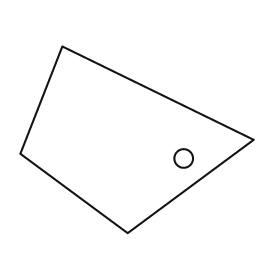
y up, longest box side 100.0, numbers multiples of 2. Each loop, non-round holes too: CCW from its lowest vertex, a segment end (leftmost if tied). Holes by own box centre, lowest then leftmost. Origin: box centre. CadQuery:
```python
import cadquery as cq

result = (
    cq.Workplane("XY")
    .moveTo(-4.0, -40.0)
    .lineTo(50.0, 0.0)
    .lineTo(-32.0, 40.0)
    .lineTo(-50.0, -6.0)
    .close()
    .moveTo(20.0, -8.0)
    .circle(4.0)
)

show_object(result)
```